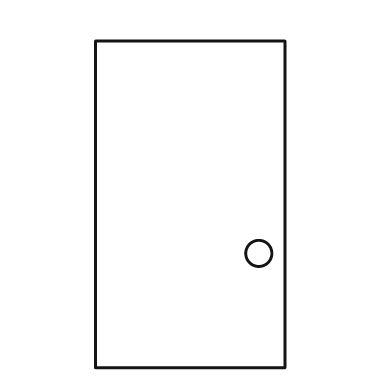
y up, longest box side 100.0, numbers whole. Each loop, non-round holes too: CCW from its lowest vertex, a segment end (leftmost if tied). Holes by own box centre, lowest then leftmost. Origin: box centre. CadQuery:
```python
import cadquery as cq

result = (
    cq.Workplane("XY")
    .moveTo(-29.0, -50.0)
    .lineTo(29.0, -50.0)
    .lineTo(29.0, 50.0)
    .lineTo(-29.0, 50.0)
    .close()
    .moveTo(21.0, -15.0)
    .circle(4.0)
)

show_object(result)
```